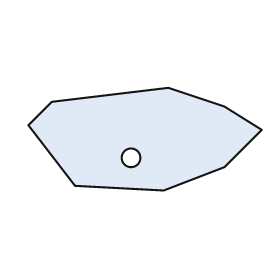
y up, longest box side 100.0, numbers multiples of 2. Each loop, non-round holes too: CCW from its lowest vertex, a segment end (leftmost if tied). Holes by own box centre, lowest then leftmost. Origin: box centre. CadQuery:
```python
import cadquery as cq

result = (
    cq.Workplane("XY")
    .moveTo(8.0, -22.0)
    .lineTo(34.0, -12.0)
    .lineTo(50.0, 4.0)
    .lineTo(34.0, 14.0)
    .lineTo(10.0, 22.0)
    .lineTo(-40.0, 16.0)
    .lineTo(-50.0, 6.0)
    .lineTo(-30.0, -20.0)
    .close()
    .moveTo(-6.0, -8.0)
    .circle(4.0)
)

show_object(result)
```